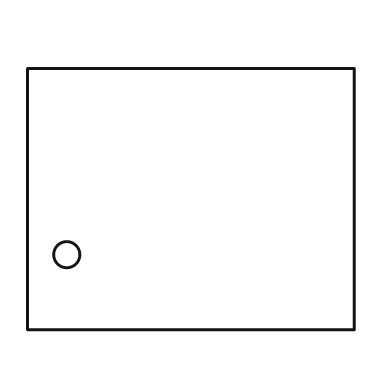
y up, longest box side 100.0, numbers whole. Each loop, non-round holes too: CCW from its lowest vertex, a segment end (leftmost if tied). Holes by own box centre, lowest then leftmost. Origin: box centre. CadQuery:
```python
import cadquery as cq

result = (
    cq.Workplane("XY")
    .moveTo(-50.0, -40.0)
    .lineTo(50.0, -40.0)
    .lineTo(50.0, 40.0)
    .lineTo(-50.0, 40.0)
    .close()
    .moveTo(-38.0, -17.0)
    .circle(4.0)
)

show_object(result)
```